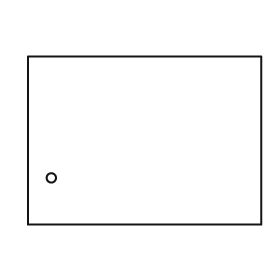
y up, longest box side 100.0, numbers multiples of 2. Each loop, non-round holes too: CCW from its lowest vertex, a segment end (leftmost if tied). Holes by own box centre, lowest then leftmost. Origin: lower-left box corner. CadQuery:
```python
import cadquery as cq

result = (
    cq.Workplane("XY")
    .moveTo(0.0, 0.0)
    .lineTo(100.0, 0.0)
    .lineTo(100.0, 72.0)
    .lineTo(0.0, 72.0)
    .close()
    .moveTo(10.0, 20.0)
    .circle(2.0)
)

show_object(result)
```